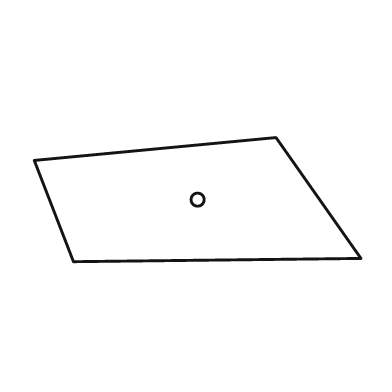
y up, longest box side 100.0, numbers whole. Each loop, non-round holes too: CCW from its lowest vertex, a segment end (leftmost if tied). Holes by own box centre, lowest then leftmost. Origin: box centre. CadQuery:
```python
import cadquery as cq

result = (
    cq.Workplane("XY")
    .moveTo(-38.0, -19.0)
    .lineTo(50.0, -18.0)
    .lineTo(24.0, 19.0)
    .lineTo(-50.0, 12.0)
    .close()
    .moveTo(0.0, 0.0)
    .circle(2.0)
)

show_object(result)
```